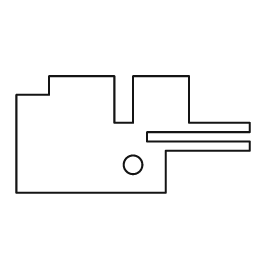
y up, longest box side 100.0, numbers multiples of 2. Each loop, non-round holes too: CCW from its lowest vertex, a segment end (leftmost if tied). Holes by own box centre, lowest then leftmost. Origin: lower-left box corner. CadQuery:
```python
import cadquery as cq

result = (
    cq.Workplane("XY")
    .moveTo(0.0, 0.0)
    .lineTo(64.0, 0.0)
    .lineTo(64.0, 18.0)
    .lineTo(100.0, 18.0)
    .lineTo(100.0, 22.0)
    .lineTo(56.0, 22.0)
    .lineTo(56.0, 26.0)
    .lineTo(100.0, 26.0)
    .lineTo(100.0, 30.0)
    .lineTo(74.0, 30.0)
    .lineTo(74.0, 50.0)
    .lineTo(50.0, 50.0)
    .lineTo(50.0, 30.0)
    .lineTo(42.0, 30.0)
    .lineTo(42.0, 50.0)
    .lineTo(14.0, 50.0)
    .lineTo(14.0, 42.0)
    .lineTo(0.0, 42.0)
    .close()
    .moveTo(50.0, 12.0)
    .circle(4.0)
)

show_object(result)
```